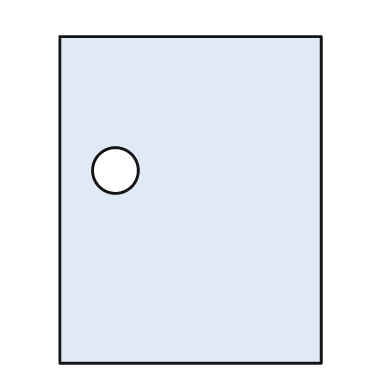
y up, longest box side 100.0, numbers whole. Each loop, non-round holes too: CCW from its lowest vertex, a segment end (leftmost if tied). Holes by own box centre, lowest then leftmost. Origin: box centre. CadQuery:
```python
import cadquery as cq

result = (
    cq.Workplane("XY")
    .moveTo(-40.0, -50.0)
    .lineTo(40.0, -50.0)
    .lineTo(40.0, 50.0)
    .lineTo(-40.0, 50.0)
    .close()
    .moveTo(-23.0, 9.0)
    .circle(7.0)
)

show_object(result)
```